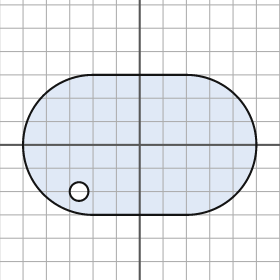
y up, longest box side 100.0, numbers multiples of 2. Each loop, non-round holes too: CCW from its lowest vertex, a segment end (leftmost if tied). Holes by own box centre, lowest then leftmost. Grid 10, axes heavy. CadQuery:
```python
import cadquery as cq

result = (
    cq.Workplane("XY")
    .moveTo(-20.0, -30.0)
    .lineTo(20.0, -30.0)
    .threePointArc((50.0, 0.0), (20.0, 30.0))
    .lineTo(-20.0, 30.0)
    .threePointArc((-50.0, 0.0), (-20.0, -30.0))
    .close()
    .moveTo(-26.0, -20.0)
    .circle(4.0)
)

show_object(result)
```